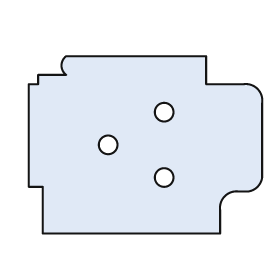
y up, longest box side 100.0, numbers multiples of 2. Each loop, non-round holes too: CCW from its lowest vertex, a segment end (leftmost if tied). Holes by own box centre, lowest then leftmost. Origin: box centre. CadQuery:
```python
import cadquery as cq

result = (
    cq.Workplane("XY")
    .moveTo(-44.0, -38.0)
    .lineTo(32.0, -38.0)
    .lineTo(32.0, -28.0)
    .threePointArc((34.0, -22.0), (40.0, -20.0))
    .lineTo(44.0, -20.0)
    .threePointArc((48.0, -18.0), (50.0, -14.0))
    .lineTo(50.0, 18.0)
    .threePointArc((48.0, 24.0), (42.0, 26.0))
    .lineTo(26.0, 26.0)
    .lineTo(26.0, 38.0)
    .lineTo(-34.0, 38.0)
    .threePointArc((-36.0, 34.0), (-34.0, 30.0))
    .lineTo(-46.0, 30.0)
    .lineTo(-46.0, 26.0)
    .lineTo(-50.0, 26.0)
    .lineTo(-50.0, -18.0)
    .lineTo(-44.0, -18.0)
    .close()
    .moveTo(8.0, -14.0)
    .circle(4.0)
    .moveTo(-16.0, 0.0)
    .circle(4.0)
    .moveTo(8.0, 14.0)
    .circle(4.0)
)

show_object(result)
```